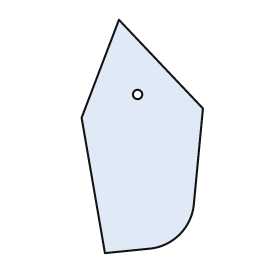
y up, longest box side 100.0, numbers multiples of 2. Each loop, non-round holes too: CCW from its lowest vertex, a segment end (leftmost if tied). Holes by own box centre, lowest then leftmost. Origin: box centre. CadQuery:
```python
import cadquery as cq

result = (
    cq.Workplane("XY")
    .moveTo(-16.0, -50.0)
    .lineTo(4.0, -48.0)
    .threePointArc((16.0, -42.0), (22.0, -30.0))
    .lineTo(26.0, 12.0)
    .lineTo(-10.0, 50.0)
    .lineTo(-26.0, 8.0)
    .close()
    .moveTo(-2.0, 18.0)
    .circle(2.0)
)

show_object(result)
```